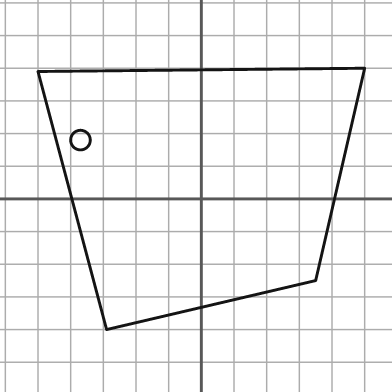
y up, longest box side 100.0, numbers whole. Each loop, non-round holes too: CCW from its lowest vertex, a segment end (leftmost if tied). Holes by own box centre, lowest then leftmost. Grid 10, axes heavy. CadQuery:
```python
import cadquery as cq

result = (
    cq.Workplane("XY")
    .moveTo(-29.0, -40.0)
    .lineTo(35.0, -25.0)
    .lineTo(50.0, 40.0)
    .lineTo(-50.0, 39.0)
    .close()
    .moveTo(-37.0, 18.0)
    .circle(3.0)
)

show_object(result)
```